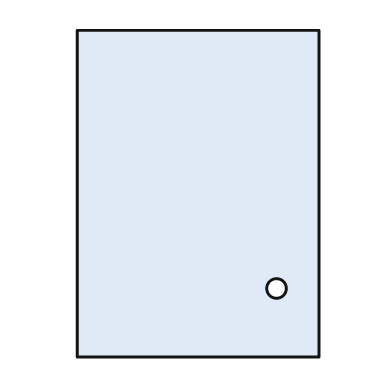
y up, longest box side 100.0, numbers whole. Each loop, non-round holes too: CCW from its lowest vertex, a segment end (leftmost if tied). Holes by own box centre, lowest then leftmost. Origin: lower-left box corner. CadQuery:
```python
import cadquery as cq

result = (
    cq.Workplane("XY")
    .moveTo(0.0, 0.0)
    .lineTo(74.0, 0.0)
    .lineTo(74.0, 100.0)
    .lineTo(0.0, 100.0)
    .close()
    .moveTo(61.0, 21.0)
    .circle(3.0)
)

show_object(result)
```